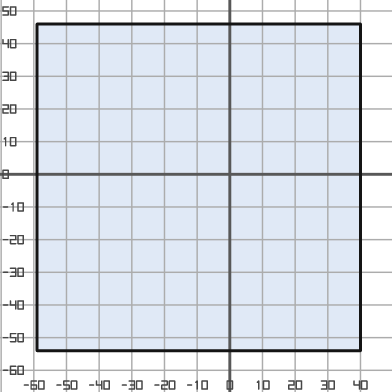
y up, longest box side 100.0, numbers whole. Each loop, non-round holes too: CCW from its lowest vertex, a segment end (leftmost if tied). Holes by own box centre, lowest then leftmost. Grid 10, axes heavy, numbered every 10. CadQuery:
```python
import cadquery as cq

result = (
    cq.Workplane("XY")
    .moveTo(-59.0, -54.0)
    .lineTo(40.0, -54.0)
    .lineTo(40.0, 46.0)
    .lineTo(-59.0, 46.0)
    .close()
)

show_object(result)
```